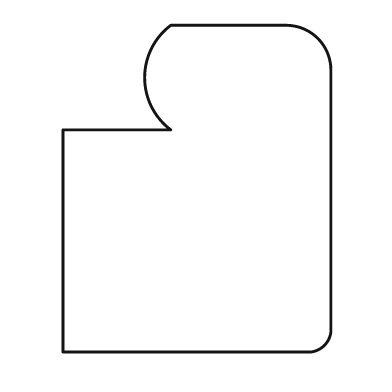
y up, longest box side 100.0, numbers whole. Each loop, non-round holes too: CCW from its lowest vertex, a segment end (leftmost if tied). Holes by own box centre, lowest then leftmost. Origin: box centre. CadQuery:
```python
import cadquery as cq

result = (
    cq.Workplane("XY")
    .moveTo(-41.0, -50.0)
    .lineTo(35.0, -50.0)
    .threePointArc((39.0, -48.0), (41.0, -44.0))
    .lineTo(41.0, 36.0)
    .threePointArc((37.0, 46.0), (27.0, 50.0))
    .lineTo(-8.0, 50.0)
    .threePointArc((-16.0, 34.0), (-8.0, 18.0))
    .lineTo(-41.0, 18.0)
    .close()
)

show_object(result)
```